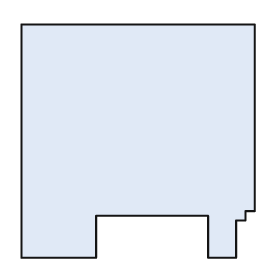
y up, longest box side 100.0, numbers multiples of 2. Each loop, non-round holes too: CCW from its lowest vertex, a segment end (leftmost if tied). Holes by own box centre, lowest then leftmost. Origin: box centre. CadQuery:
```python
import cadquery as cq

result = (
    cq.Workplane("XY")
    .moveTo(-50.0, -50.0)
    .lineTo(-18.0, -50.0)
    .lineTo(-18.0, -32.0)
    .lineTo(30.0, -32.0)
    .lineTo(30.0, -50.0)
    .lineTo(42.0, -50.0)
    .lineTo(42.0, -34.0)
    .lineTo(46.0, -34.0)
    .lineTo(46.0, -30.0)
    .lineTo(50.0, -30.0)
    .lineTo(50.0, 50.0)
    .lineTo(-50.0, 50.0)
    .close()
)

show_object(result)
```